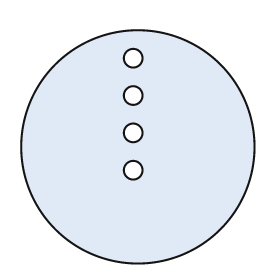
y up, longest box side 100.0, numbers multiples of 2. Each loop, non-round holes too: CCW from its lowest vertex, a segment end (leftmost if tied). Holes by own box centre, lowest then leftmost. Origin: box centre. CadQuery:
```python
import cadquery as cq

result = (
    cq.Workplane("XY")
    .moveTo(0.0, 0.0)
    .circle(50.0)
    .moveTo(-2.0, -10.0)
    .circle(4.0)
    .moveTo(-2.0, 6.0)
    .circle(4.0)
    .moveTo(-2.0, 22.0)
    .circle(4.0)
    .moveTo(-2.0, 38.0)
    .circle(4.0)
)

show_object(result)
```